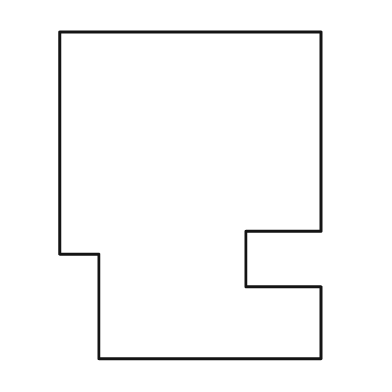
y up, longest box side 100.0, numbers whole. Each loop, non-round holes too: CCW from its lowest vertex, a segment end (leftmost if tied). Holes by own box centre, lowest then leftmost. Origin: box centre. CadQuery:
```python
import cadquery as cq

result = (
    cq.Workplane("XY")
    .moveTo(-28.0, -50.0)
    .lineTo(40.0, -50.0)
    .lineTo(40.0, -28.0)
    .lineTo(17.0, -28.0)
    .lineTo(17.0, -11.0)
    .lineTo(40.0, -11.0)
    .lineTo(40.0, 50.0)
    .lineTo(-40.0, 50.0)
    .lineTo(-40.0, -18.0)
    .lineTo(-28.0, -18.0)
    .close()
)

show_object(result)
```